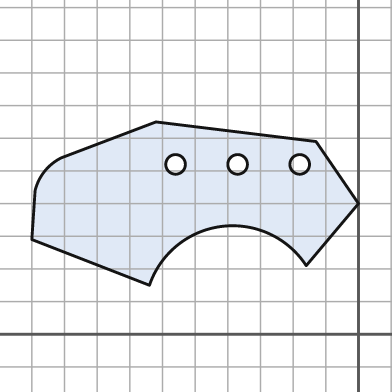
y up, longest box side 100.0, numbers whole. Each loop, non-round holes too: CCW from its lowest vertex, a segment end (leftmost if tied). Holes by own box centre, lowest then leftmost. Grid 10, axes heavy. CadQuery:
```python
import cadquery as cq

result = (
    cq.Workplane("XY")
    .moveTo(-64.0, 15.0)
    .threePointArc((-42.0, 33.0), (-16.0, 21.0))
    .lineTo(0.0, 40.0)
    .lineTo(-13.0, 59.0)
    .lineTo(-62.0, 65.0)
    .lineTo(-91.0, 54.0)
    .threePointArc((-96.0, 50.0), (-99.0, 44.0))
    .lineTo(-100.0, 29.0)
    .close()
    .moveTo(-56.0, 52.0)
    .circle(3.0)
    .moveTo(-37.0, 52.0)
    .circle(3.0)
    .moveTo(-18.0, 52.0)
    .circle(3.0)
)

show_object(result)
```